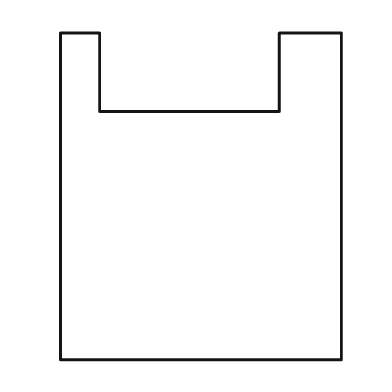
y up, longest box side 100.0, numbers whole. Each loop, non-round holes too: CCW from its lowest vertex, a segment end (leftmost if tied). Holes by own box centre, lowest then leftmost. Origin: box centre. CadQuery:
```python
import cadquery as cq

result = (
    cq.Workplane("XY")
    .moveTo(-43.0, -50.0)
    .lineTo(43.0, -50.0)
    .lineTo(43.0, 50.0)
    .lineTo(24.0, 50.0)
    .lineTo(24.0, 26.0)
    .lineTo(-31.0, 26.0)
    .lineTo(-31.0, 50.0)
    .lineTo(-43.0, 50.0)
    .close()
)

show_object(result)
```